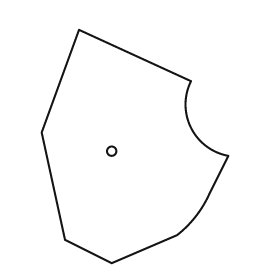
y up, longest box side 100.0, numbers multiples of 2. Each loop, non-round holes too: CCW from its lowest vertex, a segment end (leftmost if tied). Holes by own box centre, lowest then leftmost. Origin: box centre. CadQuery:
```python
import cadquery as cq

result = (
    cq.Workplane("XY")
    .moveTo(-10.0, -50.0)
    .lineTo(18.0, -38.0)
    .threePointArc((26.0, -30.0), (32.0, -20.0))
    .lineTo(40.0, -4.0)
    .threePointArc((24.0, 8.0), (24.0, 28.0))
    .lineTo(-24.0, 50.0)
    .lineTo(-40.0, 6.0)
    .lineTo(-30.0, -40.0)
    .close()
    .moveTo(-10.0, -2.0)
    .circle(2.0)
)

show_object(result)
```